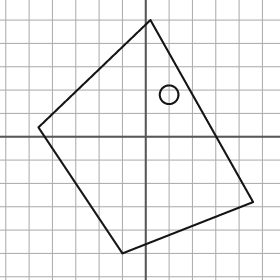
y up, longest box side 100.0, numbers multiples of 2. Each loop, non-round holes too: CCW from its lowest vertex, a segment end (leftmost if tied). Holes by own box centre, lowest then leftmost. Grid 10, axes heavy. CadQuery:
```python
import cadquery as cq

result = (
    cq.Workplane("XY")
    .moveTo(-10.0, -50.0)
    .lineTo(46.0, -28.0)
    .lineTo(2.0, 50.0)
    .lineTo(-46.0, 4.0)
    .close()
    .moveTo(10.0, 18.0)
    .circle(4.0)
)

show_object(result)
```